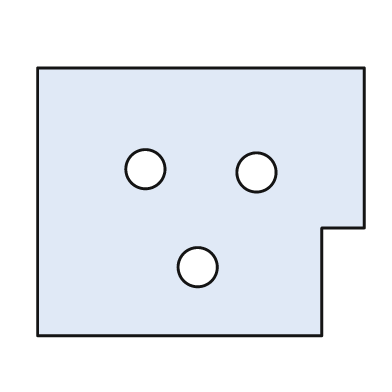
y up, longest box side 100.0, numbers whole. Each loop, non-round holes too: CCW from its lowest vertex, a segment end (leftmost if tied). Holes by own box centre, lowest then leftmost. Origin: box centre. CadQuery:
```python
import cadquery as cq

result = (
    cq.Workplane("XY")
    .moveTo(-50.0, -41.0)
    .lineTo(37.0, -41.0)
    .lineTo(37.0, -8.0)
    .lineTo(50.0, -8.0)
    .lineTo(50.0, 41.0)
    .lineTo(-50.0, 41.0)
    .close()
    .moveTo(-1.0, -20.0)
    .circle(6.0)
    .moveTo(17.0, 9.0)
    .circle(6.0)
    .moveTo(-17.0, 10.0)
    .circle(6.0)
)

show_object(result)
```